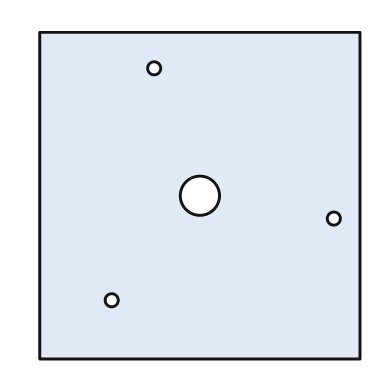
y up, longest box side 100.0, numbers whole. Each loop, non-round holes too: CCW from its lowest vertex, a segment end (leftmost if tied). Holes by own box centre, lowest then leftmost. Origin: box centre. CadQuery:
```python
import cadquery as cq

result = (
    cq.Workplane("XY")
    .moveTo(-49.0, -50.0)
    .lineTo(49.0, -50.0)
    .lineTo(49.0, 50.0)
    .lineTo(-49.0, 50.0)
    .close()
    .moveTo(-27.0, -32.0)
    .circle(2.0)
    .moveTo(41.0, -7.0)
    .circle(2.0)
    .moveTo(0.0, 0.0)
    .circle(6.0)
    .moveTo(-14.0, 39.0)
    .circle(2.0)
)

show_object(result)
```